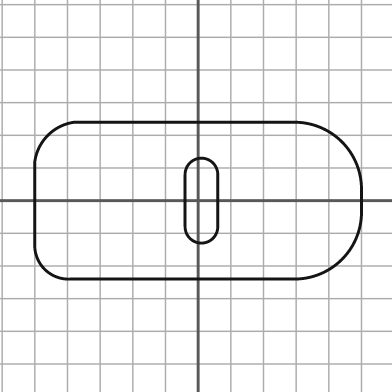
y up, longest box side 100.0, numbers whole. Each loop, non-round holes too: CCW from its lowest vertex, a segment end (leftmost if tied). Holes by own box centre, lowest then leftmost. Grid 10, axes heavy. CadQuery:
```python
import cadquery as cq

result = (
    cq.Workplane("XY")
    .moveTo(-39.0, -24.0)
    .lineTo(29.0, -24.0)
    .threePointArc((44.0, -18.0), (50.0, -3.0))
    .lineTo(50.0, 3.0)
    .threePointArc((44.0, 18.0), (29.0, 24.0))
    .lineTo(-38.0, 24.0)
    .threePointArc((-46.0, 20.0), (-50.0, 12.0))
    .lineTo(-50.0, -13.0)
    .threePointArc((-47.0, -21.0), (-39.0, -24.0))
    .close()
    .moveTo(-4.0, -8.0)
    .threePointArc((1.0, -13.0), (6.0, -8.0))
    .lineTo(6.0, 8.0)
    .threePointArc((1.0, 13.0), (-4.0, 8.0))
    .close()
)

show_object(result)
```